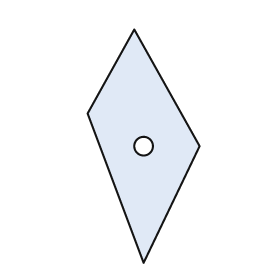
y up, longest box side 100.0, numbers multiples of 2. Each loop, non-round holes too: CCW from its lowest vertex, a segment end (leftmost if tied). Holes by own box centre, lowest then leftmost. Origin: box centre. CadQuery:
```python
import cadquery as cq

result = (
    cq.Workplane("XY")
    .moveTo(0.0, -50.0)
    .lineTo(24.0, 0.0)
    .lineTo(-4.0, 50.0)
    .lineTo(-24.0, 14.0)
    .close()
    .moveTo(0.0, 0.0)
    .circle(4.0)
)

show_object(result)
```